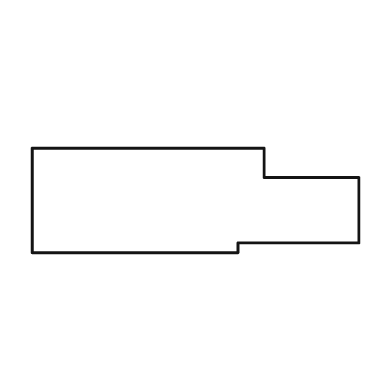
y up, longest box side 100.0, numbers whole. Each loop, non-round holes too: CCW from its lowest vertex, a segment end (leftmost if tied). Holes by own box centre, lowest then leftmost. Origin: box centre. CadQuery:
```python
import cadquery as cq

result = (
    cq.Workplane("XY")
    .moveTo(-50.0, -16.0)
    .lineTo(13.0, -16.0)
    .lineTo(13.0, -13.0)
    .lineTo(50.0, -13.0)
    .lineTo(50.0, 7.0)
    .lineTo(21.0, 7.0)
    .lineTo(21.0, 16.0)
    .lineTo(-50.0, 16.0)
    .close()
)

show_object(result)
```